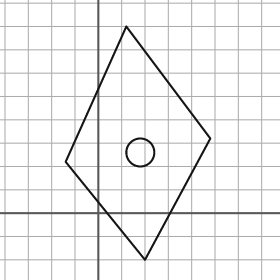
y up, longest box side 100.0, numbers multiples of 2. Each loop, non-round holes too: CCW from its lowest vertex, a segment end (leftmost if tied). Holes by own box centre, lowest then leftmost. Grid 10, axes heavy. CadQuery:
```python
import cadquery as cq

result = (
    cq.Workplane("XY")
    .moveTo(20.0, -20.0)
    .lineTo(48.0, 32.0)
    .lineTo(12.0, 80.0)
    .lineTo(-14.0, 22.0)
    .close()
    .moveTo(18.0, 26.0)
    .circle(6.0)
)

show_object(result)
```